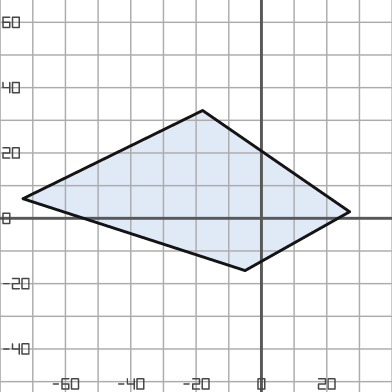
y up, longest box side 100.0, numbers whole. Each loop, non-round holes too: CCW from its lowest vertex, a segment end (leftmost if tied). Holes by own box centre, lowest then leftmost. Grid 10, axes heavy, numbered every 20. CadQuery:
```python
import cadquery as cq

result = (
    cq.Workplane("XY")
    .moveTo(-5.0, -16.0)
    .lineTo(27.0, 2.0)
    .lineTo(-18.0, 33.0)
    .lineTo(-73.0, 6.0)
    .close()
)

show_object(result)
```